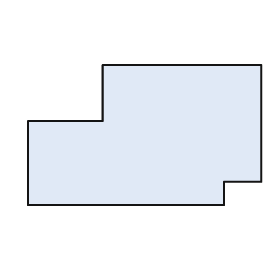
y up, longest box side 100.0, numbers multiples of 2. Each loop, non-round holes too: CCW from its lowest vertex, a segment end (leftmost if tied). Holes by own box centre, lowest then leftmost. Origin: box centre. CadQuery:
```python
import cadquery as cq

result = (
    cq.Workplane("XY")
    .moveTo(-50.0, -30.0)
    .lineTo(34.0, -30.0)
    .lineTo(34.0, -20.0)
    .lineTo(50.0, -20.0)
    .lineTo(50.0, 30.0)
    .lineTo(-18.0, 30.0)
    .lineTo(-18.0, 6.0)
    .lineTo(-50.0, 6.0)
    .close()
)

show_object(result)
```